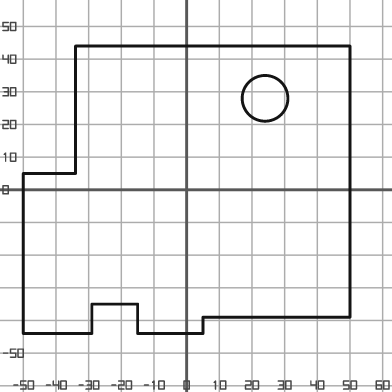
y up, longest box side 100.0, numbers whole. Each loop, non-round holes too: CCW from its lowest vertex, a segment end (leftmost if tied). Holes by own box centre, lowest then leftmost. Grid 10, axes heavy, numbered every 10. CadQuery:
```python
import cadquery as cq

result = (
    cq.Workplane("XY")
    .moveTo(-50.0, -44.0)
    .lineTo(-29.0, -44.0)
    .lineTo(-29.0, -35.0)
    .lineTo(-15.0, -35.0)
    .lineTo(-15.0, -44.0)
    .lineTo(5.0, -44.0)
    .lineTo(5.0, -39.0)
    .lineTo(50.0, -39.0)
    .lineTo(50.0, 44.0)
    .lineTo(-34.0, 44.0)
    .lineTo(-34.0, 5.0)
    .lineTo(-50.0, 5.0)
    .close()
    .moveTo(24.0, 28.0)
    .circle(7.0)
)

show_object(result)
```